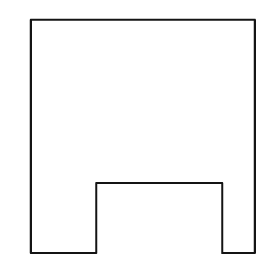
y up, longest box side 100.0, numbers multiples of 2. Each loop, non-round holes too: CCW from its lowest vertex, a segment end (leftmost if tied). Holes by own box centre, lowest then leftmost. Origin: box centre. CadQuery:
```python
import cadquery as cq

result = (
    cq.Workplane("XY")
    .moveTo(-48.0, -50.0)
    .lineTo(-20.0, -50.0)
    .lineTo(-20.0, -20.0)
    .lineTo(34.0, -20.0)
    .lineTo(34.0, -50.0)
    .lineTo(48.0, -50.0)
    .lineTo(48.0, 50.0)
    .lineTo(-48.0, 50.0)
    .close()
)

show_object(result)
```